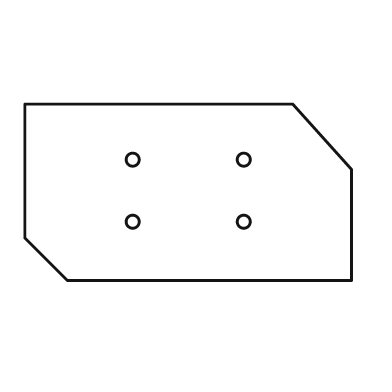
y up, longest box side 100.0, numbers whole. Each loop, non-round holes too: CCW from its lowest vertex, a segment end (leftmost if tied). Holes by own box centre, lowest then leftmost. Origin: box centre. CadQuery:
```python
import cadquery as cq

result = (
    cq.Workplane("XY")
    .moveTo(-37.0, -27.0)
    .lineTo(50.0, -27.0)
    .lineTo(50.0, 7.0)
    .lineTo(32.0, 27.0)
    .lineTo(-50.0, 27.0)
    .lineTo(-50.0, -14.0)
    .close()
    .moveTo(-17.0, -9.0)
    .circle(2.0)
    .moveTo(17.0, -9.0)
    .circle(2.0)
    .moveTo(-17.0, 10.0)
    .circle(2.0)
    .moveTo(17.0, 10.0)
    .circle(2.0)
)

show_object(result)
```